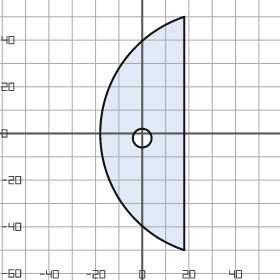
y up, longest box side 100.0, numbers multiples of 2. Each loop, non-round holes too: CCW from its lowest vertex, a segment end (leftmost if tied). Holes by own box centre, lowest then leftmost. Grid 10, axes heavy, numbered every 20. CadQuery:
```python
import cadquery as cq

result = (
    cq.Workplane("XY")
    .moveTo(18.0, -50.0)
    .lineTo(18.0, 50.0)
    .threePointArc((-18.0, 0.0), (18.0, -50.0))
    .close()
    .moveTo(0.0, -2.0)
    .circle(4.0)
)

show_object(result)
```